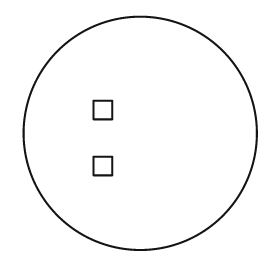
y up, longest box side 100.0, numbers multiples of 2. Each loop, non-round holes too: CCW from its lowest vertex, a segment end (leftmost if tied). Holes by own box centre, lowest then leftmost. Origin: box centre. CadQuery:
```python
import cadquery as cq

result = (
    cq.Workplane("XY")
    .moveTo(0.0, 0.0)
    .circle(50.0)
    .moveTo(-20.0, -18.0)
    .lineTo(-12.0, -18.0)
    .lineTo(-12.0, -10.0)
    .lineTo(-20.0, -10.0)
    .close()
    .moveTo(-20.0, 6.0)
    .lineTo(-12.0, 6.0)
    .lineTo(-12.0, 14.0)
    .lineTo(-20.0, 14.0)
    .close()
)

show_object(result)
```